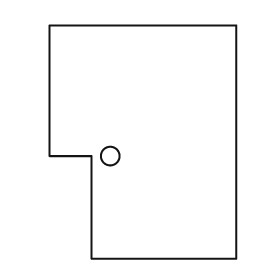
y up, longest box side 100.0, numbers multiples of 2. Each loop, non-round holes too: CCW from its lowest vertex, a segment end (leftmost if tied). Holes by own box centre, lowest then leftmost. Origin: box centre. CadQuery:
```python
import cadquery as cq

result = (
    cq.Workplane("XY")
    .moveTo(-22.0, -50.0)
    .lineTo(40.0, -50.0)
    .lineTo(40.0, 50.0)
    .lineTo(-40.0, 50.0)
    .lineTo(-40.0, -6.0)
    .lineTo(-22.0, -6.0)
    .close()
    .moveTo(-14.0, -6.0)
    .circle(4.0)
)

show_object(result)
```